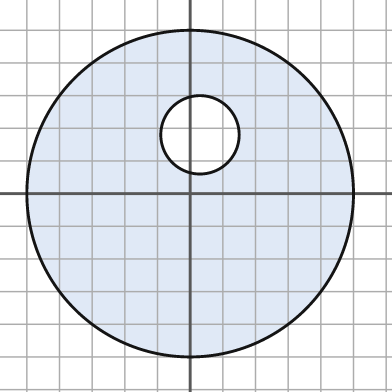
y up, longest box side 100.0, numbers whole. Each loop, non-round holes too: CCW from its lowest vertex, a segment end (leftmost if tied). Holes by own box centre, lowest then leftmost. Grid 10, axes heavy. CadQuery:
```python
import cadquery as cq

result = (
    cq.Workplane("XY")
    .moveTo(0.0, 0.0)
    .circle(50.0)
    .moveTo(3.0, 18.0)
    .circle(12.0)
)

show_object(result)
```